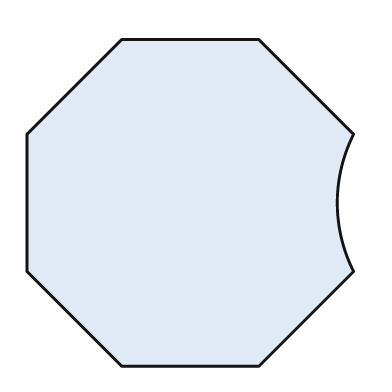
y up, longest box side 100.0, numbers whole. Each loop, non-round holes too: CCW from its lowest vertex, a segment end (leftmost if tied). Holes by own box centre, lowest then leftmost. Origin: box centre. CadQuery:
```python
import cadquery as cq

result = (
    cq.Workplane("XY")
    .moveTo(-21.0, -50.0)
    .lineTo(21.0, -50.0)
    .lineTo(50.0, -21.0)
    .threePointArc((45.0, 0.0), (50.0, 21.0))
    .lineTo(21.0, 50.0)
    .lineTo(-21.0, 50.0)
    .lineTo(-50.0, 21.0)
    .lineTo(-50.0, -21.0)
    .close()
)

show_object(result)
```